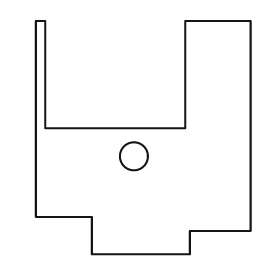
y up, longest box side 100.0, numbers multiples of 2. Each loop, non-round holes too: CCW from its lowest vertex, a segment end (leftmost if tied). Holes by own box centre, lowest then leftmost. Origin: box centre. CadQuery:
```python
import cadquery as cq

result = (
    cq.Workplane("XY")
    .moveTo(-22.0, -50.0)
    .lineTo(20.0, -50.0)
    .lineTo(20.0, -40.0)
    .lineTo(46.0, -40.0)
    .lineTo(46.0, 50.0)
    .lineTo(18.0, 50.0)
    .lineTo(18.0, 4.0)
    .lineTo(-42.0, 4.0)
    .lineTo(-42.0, 50.0)
    .lineTo(-46.0, 50.0)
    .lineTo(-46.0, -34.0)
    .lineTo(-22.0, -34.0)
    .close()
    .moveTo(-4.0, -8.0)
    .circle(6.0)
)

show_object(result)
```